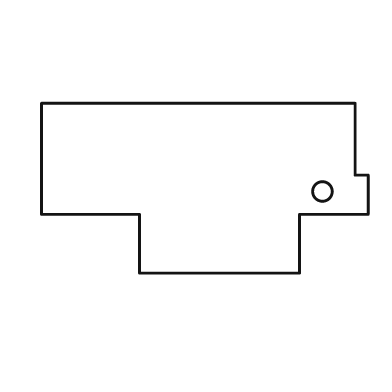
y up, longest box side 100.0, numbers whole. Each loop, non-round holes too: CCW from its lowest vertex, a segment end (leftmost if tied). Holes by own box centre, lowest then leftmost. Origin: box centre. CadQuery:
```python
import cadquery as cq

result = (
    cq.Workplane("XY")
    .moveTo(-20.0, -26.0)
    .lineTo(29.0, -26.0)
    .lineTo(29.0, -8.0)
    .lineTo(50.0, -8.0)
    .lineTo(50.0, 4.0)
    .lineTo(46.0, 4.0)
    .lineTo(46.0, 26.0)
    .lineTo(-50.0, 26.0)
    .lineTo(-50.0, -8.0)
    .lineTo(-20.0, -8.0)
    .close()
    .moveTo(36.0, -1.0)
    .circle(3.0)
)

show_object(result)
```